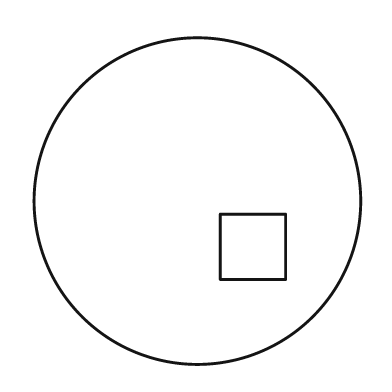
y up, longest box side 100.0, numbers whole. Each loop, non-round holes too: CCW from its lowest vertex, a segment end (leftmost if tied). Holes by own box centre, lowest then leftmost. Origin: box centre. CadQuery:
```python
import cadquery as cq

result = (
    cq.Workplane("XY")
    .moveTo(0.0, 0.0)
    .circle(50.0)
    .moveTo(7.0, -24.0)
    .lineTo(27.0, -24.0)
    .lineTo(27.0, -4.0)
    .lineTo(7.0, -4.0)
    .close()
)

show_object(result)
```